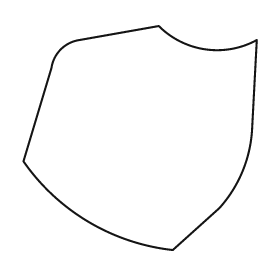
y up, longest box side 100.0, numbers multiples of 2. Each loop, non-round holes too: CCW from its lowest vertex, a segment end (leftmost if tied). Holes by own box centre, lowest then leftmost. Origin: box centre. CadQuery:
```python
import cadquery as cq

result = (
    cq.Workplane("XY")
    .moveTo(14.0, -48.0)
    .lineTo(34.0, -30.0)
    .threePointArc((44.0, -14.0), (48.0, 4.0))
    .lineTo(50.0, 42.0)
    .threePointArc((28.0, 38.0), (8.0, 48.0))
    .lineTo(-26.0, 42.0)
    .threePointArc((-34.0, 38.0), (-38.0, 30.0))
    .lineTo(-50.0, -10.0)
    .threePointArc((-22.0, -36.0), (14.0, -48.0))
    .close()
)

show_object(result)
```